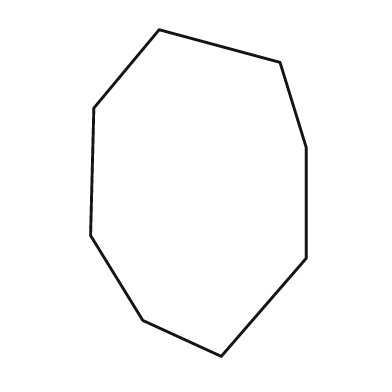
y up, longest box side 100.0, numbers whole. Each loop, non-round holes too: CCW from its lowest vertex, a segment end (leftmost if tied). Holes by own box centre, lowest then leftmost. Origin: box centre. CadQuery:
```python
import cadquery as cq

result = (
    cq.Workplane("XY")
    .moveTo(7.0, -50.0)
    .lineTo(33.0, -20.0)
    .lineTo(33.0, 14.0)
    .lineTo(25.0, 40.0)
    .lineTo(-12.0, 50.0)
    .lineTo(-32.0, 26.0)
    .lineTo(-33.0, -13.0)
    .lineTo(-17.0, -39.0)
    .close()
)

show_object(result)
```